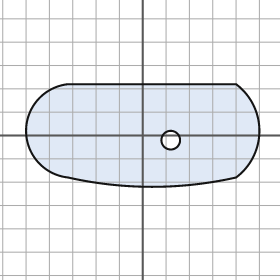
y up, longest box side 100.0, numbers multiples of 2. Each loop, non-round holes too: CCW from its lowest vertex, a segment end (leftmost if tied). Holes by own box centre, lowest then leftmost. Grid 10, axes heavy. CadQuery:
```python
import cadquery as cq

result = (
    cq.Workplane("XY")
    .moveTo(-32.0, -18.0)
    .threePointArc((4.0, -22.0), (40.0, -18.0))
    .threePointArc((50.0, 2.0), (40.0, 22.0))
    .lineTo(-32.0, 22.0)
    .threePointArc((-50.0, 2.0), (-32.0, -18.0))
    .close()
    .moveTo(12.0, -2.0)
    .circle(4.0)
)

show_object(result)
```